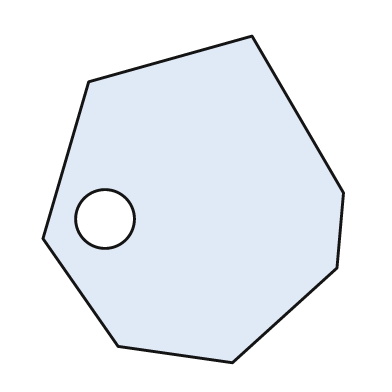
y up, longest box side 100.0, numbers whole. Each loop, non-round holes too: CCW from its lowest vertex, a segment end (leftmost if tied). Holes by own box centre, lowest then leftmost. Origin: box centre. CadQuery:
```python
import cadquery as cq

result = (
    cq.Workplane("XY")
    .moveTo(12.0, -50.0)
    .lineTo(44.0, -21.0)
    .lineTo(46.0, 2.0)
    .lineTo(18.0, 50.0)
    .lineTo(-32.0, 36.0)
    .lineTo(-46.0, -12.0)
    .lineTo(-23.0, -45.0)
    .close()
    .moveTo(-27.0, -6.0)
    .circle(9.0)
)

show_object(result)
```